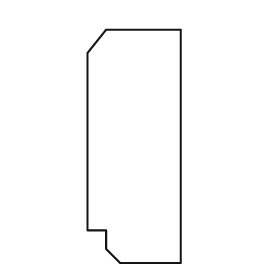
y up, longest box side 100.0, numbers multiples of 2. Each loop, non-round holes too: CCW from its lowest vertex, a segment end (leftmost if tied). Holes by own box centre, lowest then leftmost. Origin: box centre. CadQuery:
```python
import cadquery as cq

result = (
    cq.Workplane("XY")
    .moveTo(-6.0, -50.0)
    .lineTo(20.0, -50.0)
    .lineTo(20.0, 50.0)
    .lineTo(-12.0, 50.0)
    .lineTo(-20.0, 40.0)
    .lineTo(-20.0, -36.0)
    .lineTo(-12.0, -36.0)
    .lineTo(-12.0, -44.0)
    .close()
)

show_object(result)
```